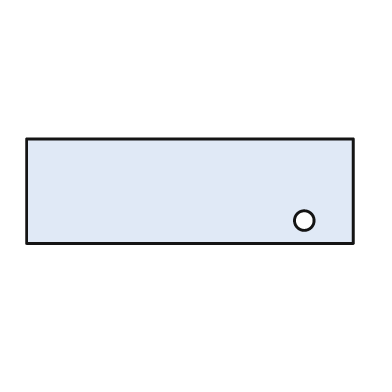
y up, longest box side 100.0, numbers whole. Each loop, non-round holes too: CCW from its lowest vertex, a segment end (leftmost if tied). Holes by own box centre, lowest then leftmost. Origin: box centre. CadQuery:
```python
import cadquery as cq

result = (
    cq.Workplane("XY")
    .moveTo(-50.0, -16.0)
    .lineTo(50.0, -16.0)
    .lineTo(50.0, 16.0)
    .lineTo(-50.0, 16.0)
    .close()
    .moveTo(35.0, -9.0)
    .circle(3.0)
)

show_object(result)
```